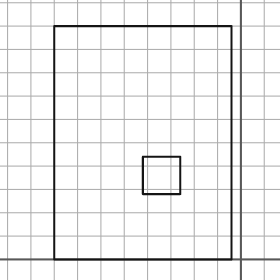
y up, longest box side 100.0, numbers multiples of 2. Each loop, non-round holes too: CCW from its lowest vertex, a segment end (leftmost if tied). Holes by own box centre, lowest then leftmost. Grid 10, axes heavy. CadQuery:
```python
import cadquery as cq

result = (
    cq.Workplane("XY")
    .moveTo(-80.0, 0.0)
    .lineTo(-4.0, 0.0)
    .lineTo(-4.0, 100.0)
    .lineTo(-80.0, 100.0)
    .close()
    .moveTo(-42.0, 28.0)
    .lineTo(-26.0, 28.0)
    .lineTo(-26.0, 44.0)
    .lineTo(-42.0, 44.0)
    .close()
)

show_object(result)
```